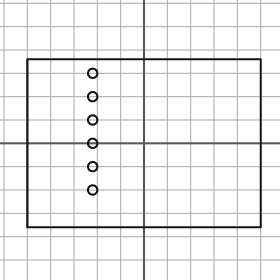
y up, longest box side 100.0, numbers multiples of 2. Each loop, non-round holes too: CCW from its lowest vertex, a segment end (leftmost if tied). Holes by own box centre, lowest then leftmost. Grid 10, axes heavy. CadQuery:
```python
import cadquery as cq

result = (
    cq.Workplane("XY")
    .moveTo(-50.0, -36.0)
    .lineTo(50.0, -36.0)
    .lineTo(50.0, 36.0)
    .lineTo(-50.0, 36.0)
    .close()
    .moveTo(-22.0, -20.0)
    .circle(2.0)
    .moveTo(-22.0, -10.0)
    .circle(2.0)
    .moveTo(-22.0, 0.0)
    .circle(2.0)
    .moveTo(-22.0, 10.0)
    .circle(2.0)
    .moveTo(-22.0, 20.0)
    .circle(2.0)
    .moveTo(-22.0, 30.0)
    .circle(2.0)
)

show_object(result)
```